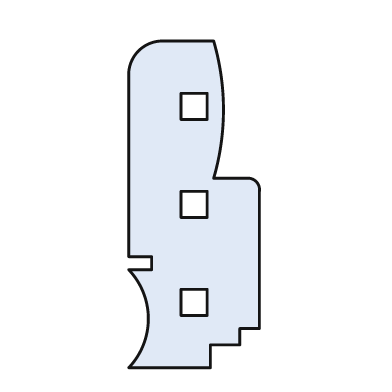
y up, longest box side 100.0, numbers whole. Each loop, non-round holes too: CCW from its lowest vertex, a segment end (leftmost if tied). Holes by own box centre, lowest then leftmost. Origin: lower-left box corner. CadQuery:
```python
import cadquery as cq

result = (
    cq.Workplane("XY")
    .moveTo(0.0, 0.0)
    .lineTo(25.0, 0.0)
    .lineTo(25.0, 7.0)
    .lineTo(34.0, 7.0)
    .lineTo(34.0, 12.0)
    .lineTo(40.0, 12.0)
    .lineTo(40.0, 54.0)
    .threePointArc((39.0, 57.0), (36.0, 58.0))
    .lineTo(26.0, 58.0)
    .threePointArc((29.0, 79.0), (26.0, 100.0))
    .lineTo(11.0, 100.0)
    .threePointArc((3.0, 97.0), (0.0, 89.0))
    .lineTo(0.0, 34.0)
    .lineTo(7.0, 34.0)
    .lineTo(7.0, 30.0)
    .lineTo(0.0, 30.0)
    .threePointArc((6.0, 15.0), (0.0, 0.0))
    .close()
    .moveTo(16.0, 16.0)
    .lineTo(24.0, 16.0)
    .lineTo(24.0, 24.0)
    .lineTo(16.0, 24.0)
    .close()
    .moveTo(16.0, 46.0)
    .lineTo(24.0, 46.0)
    .lineTo(24.0, 54.0)
    .lineTo(16.0, 54.0)
    .close()
    .moveTo(16.0, 76.0)
    .lineTo(24.0, 76.0)
    .lineTo(24.0, 84.0)
    .lineTo(16.0, 84.0)
    .close()
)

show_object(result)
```